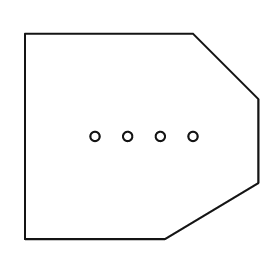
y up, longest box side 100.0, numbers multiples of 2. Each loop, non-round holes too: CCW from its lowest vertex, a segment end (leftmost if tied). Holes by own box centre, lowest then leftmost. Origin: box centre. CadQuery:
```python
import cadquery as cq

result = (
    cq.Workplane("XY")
    .moveTo(-50.0, -44.0)
    .lineTo(10.0, -44.0)
    .lineTo(50.0, -20.0)
    .lineTo(50.0, 16.0)
    .lineTo(22.0, 44.0)
    .lineTo(-50.0, 44.0)
    .close()
    .moveTo(-20.0, 0.0)
    .circle(2.0)
    .moveTo(-6.0, 0.0)
    .circle(2.0)
    .moveTo(8.0, 0.0)
    .circle(2.0)
    .moveTo(22.0, 0.0)
    .circle(2.0)
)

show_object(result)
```